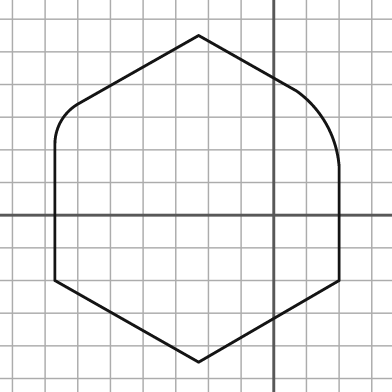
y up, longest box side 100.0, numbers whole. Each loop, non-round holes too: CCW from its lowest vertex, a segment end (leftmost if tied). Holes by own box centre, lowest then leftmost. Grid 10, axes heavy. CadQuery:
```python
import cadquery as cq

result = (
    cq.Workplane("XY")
    .moveTo(-23.0, -45.0)
    .lineTo(20.0, -20.0)
    .lineTo(20.0, 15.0)
    .threePointArc((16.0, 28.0), (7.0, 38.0))
    .lineTo(-23.0, 55.0)
    .lineTo(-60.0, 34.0)
    .threePointArc((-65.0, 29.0), (-67.0, 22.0))
    .lineTo(-67.0, -20.0)
    .close()
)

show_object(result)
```